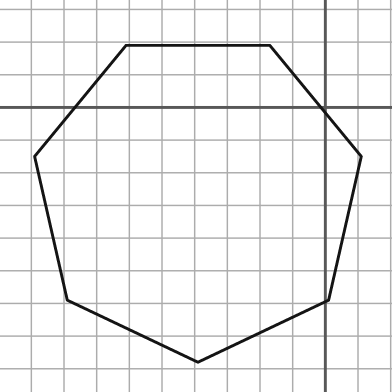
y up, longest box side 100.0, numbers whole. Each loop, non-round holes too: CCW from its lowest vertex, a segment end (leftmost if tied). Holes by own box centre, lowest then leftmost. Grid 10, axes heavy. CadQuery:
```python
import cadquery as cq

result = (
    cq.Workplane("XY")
    .moveTo(-39.0, -78.0)
    .lineTo(1.0, -59.0)
    .lineTo(11.0, -15.0)
    .lineTo(-17.0, 19.0)
    .lineTo(-61.0, 19.0)
    .lineTo(-89.0, -15.0)
    .lineTo(-79.0, -59.0)
    .close()
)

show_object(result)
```